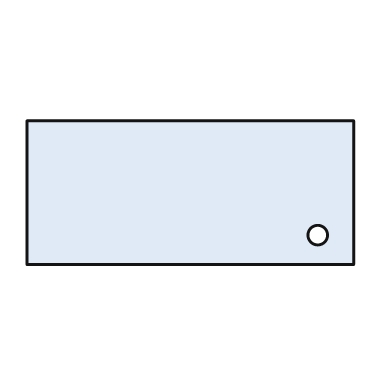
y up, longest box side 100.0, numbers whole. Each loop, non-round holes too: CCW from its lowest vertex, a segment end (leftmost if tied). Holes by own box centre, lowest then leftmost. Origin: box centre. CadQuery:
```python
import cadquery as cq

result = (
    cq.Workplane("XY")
    .moveTo(-50.0, -22.0)
    .lineTo(50.0, -22.0)
    .lineTo(50.0, 22.0)
    .lineTo(-50.0, 22.0)
    .close()
    .moveTo(39.0, -13.0)
    .circle(3.0)
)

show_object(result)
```